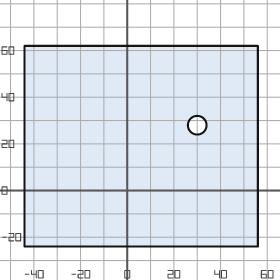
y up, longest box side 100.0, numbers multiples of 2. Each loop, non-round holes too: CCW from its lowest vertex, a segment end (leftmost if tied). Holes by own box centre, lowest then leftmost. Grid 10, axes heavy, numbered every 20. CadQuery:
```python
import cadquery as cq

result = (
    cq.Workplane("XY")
    .moveTo(-44.0, -24.0)
    .lineTo(56.0, -24.0)
    .lineTo(56.0, 62.0)
    .lineTo(-44.0, 62.0)
    .close()
    .moveTo(30.0, 28.0)
    .circle(4.0)
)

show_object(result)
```